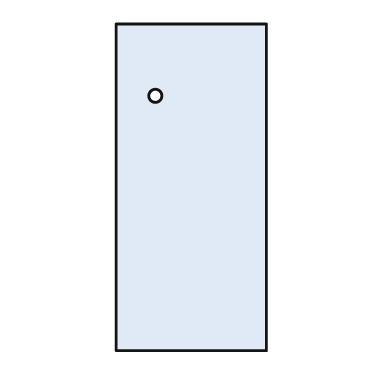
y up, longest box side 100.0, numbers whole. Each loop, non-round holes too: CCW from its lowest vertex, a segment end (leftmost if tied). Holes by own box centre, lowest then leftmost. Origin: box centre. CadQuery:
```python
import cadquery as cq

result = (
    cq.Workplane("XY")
    .moveTo(-23.0, -50.0)
    .lineTo(23.0, -50.0)
    .lineTo(23.0, 50.0)
    .lineTo(-23.0, 50.0)
    .close()
    .moveTo(-11.0, 28.0)
    .circle(2.0)
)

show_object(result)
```